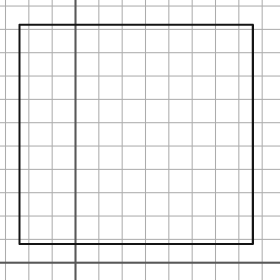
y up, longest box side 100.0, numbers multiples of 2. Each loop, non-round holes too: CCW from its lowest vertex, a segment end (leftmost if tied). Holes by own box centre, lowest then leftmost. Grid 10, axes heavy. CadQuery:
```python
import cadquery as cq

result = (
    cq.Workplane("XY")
    .moveTo(-24.0, 8.0)
    .lineTo(76.0, 8.0)
    .lineTo(76.0, 102.0)
    .lineTo(-24.0, 102.0)
    .close()
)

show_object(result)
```